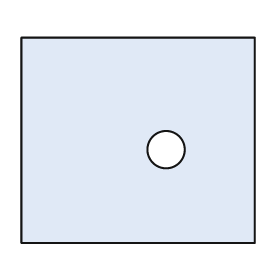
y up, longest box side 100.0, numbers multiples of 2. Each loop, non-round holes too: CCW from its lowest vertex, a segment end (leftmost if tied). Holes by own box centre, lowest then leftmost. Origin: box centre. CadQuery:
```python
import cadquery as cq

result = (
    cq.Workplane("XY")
    .moveTo(-50.0, -44.0)
    .lineTo(50.0, -44.0)
    .lineTo(50.0, 44.0)
    .lineTo(-50.0, 44.0)
    .close()
    .moveTo(12.0, -4.0)
    .circle(8.0)
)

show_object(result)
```